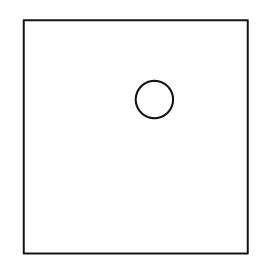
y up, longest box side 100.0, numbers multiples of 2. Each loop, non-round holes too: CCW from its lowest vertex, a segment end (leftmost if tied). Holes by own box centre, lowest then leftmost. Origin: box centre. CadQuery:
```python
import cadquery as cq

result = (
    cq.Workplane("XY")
    .moveTo(-48.0, -50.0)
    .lineTo(48.0, -50.0)
    .lineTo(48.0, 50.0)
    .lineTo(-48.0, 50.0)
    .close()
    .moveTo(8.0, 16.0)
    .circle(8.0)
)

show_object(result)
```